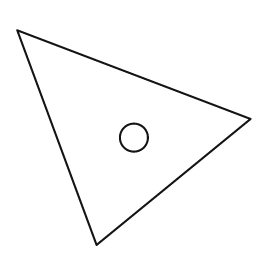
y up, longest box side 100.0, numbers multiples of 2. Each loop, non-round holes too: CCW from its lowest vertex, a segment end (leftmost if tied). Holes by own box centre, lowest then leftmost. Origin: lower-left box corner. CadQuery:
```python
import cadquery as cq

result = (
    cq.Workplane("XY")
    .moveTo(34.0, 0.0)
    .lineTo(100.0, 54.0)
    .lineTo(0.0, 92.0)
    .close()
    .moveTo(50.0, 46.0)
    .circle(6.0)
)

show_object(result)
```